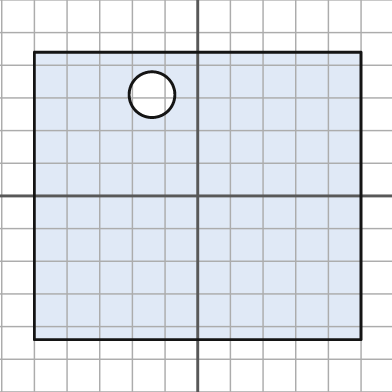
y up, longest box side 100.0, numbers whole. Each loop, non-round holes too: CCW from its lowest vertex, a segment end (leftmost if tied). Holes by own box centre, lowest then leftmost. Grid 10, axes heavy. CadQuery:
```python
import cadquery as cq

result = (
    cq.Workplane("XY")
    .moveTo(-50.0, -44.0)
    .lineTo(50.0, -44.0)
    .lineTo(50.0, 44.0)
    .lineTo(-50.0, 44.0)
    .close()
    .moveTo(-14.0, 31.0)
    .circle(7.0)
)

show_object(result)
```